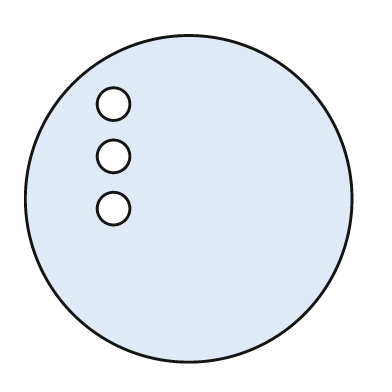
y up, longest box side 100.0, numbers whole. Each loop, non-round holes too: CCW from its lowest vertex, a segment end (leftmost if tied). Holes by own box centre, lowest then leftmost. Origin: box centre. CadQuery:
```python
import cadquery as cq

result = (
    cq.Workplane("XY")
    .moveTo(0.0, 0.0)
    .circle(50.0)
    .moveTo(-23.0, -3.0)
    .circle(5.0)
    .moveTo(-23.0, 13.0)
    .circle(5.0)
    .moveTo(-23.0, 29.0)
    .circle(5.0)
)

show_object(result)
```